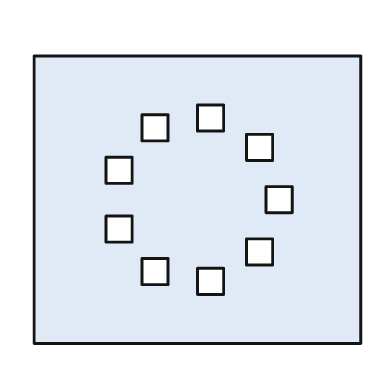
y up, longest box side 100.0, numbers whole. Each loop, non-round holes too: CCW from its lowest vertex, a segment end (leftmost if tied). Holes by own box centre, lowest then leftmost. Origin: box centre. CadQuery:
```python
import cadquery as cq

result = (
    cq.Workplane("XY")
    .moveTo(-50.0, -44.0)
    .lineTo(50.0, -44.0)
    .lineTo(50.0, 44.0)
    .lineTo(-50.0, 44.0)
    .close()
    .moveTo(0.0, -29.0)
    .lineTo(8.0, -29.0)
    .lineTo(8.0, -21.0)
    .lineTo(0.0, -21.0)
    .close()
    .moveTo(-17.0, -26.0)
    .lineTo(-9.0, -26.0)
    .lineTo(-9.0, -18.0)
    .lineTo(-17.0, -18.0)
    .close()
    .moveTo(15.0, -20.0)
    .lineTo(23.0, -20.0)
    .lineTo(23.0, -12.0)
    .lineTo(15.0, -12.0)
    .close()
    .moveTo(-28.0, -13.0)
    .lineTo(-20.0, -13.0)
    .lineTo(-20.0, -5.0)
    .lineTo(-28.0, -5.0)
    .close()
    .moveTo(21.0, -4.0)
    .lineTo(29.0, -4.0)
    .lineTo(29.0, 4.0)
    .lineTo(21.0, 4.0)
    .close()
    .moveTo(-28.0, 5.0)
    .lineTo(-20.0, 5.0)
    .lineTo(-20.0, 13.0)
    .lineTo(-28.0, 13.0)
    .close()
    .moveTo(15.0, 12.0)
    .lineTo(23.0, 12.0)
    .lineTo(23.0, 20.0)
    .lineTo(15.0, 20.0)
    .close()
    .moveTo(-17.0, 18.0)
    .lineTo(-9.0, 18.0)
    .lineTo(-9.0, 26.0)
    .lineTo(-17.0, 26.0)
    .close()
    .moveTo(0.0, 21.0)
    .lineTo(8.0, 21.0)
    .lineTo(8.0, 29.0)
    .lineTo(0.0, 29.0)
    .close()
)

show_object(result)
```